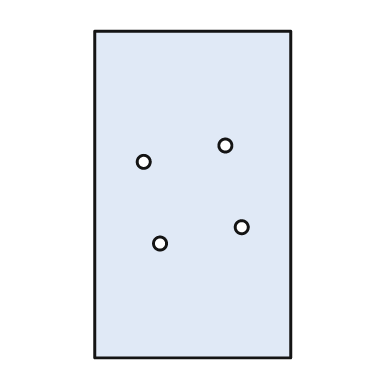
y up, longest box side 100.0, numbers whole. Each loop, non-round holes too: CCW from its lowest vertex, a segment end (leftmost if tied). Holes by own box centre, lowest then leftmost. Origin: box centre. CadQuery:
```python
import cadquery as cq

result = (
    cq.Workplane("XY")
    .moveTo(-30.0, -50.0)
    .lineTo(30.0, -50.0)
    .lineTo(30.0, 50.0)
    .lineTo(-30.0, 50.0)
    .close()
    .moveTo(-10.0, -15.0)
    .circle(2.0)
    .moveTo(15.0, -10.0)
    .circle(2.0)
    .moveTo(-15.0, 10.0)
    .circle(2.0)
    .moveTo(10.0, 15.0)
    .circle(2.0)
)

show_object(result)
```